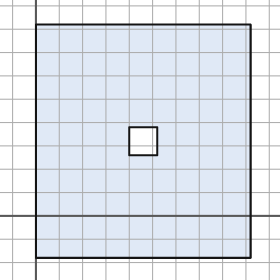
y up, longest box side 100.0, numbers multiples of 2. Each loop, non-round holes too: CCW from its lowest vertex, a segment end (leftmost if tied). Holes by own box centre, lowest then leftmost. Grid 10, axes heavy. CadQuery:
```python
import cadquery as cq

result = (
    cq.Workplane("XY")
    .moveTo(0.0, -18.0)
    .lineTo(92.0, -18.0)
    .lineTo(92.0, 82.0)
    .lineTo(0.0, 82.0)
    .close()
    .moveTo(40.0, 26.0)
    .lineTo(52.0, 26.0)
    .lineTo(52.0, 38.0)
    .lineTo(40.0, 38.0)
    .close()
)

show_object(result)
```